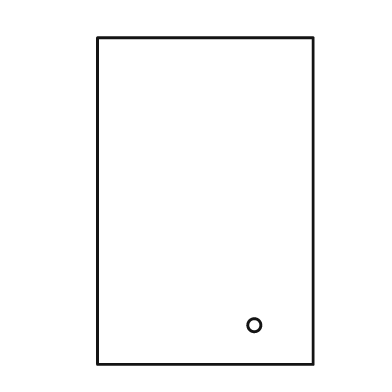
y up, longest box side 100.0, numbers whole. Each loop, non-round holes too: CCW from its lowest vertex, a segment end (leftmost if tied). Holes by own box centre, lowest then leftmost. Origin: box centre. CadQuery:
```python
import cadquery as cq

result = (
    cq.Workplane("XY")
    .moveTo(-33.0, -50.0)
    .lineTo(33.0, -50.0)
    .lineTo(33.0, 50.0)
    .lineTo(-33.0, 50.0)
    .close()
    .moveTo(15.0, -38.0)
    .circle(2.0)
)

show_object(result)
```